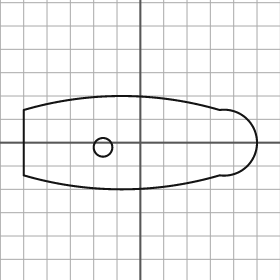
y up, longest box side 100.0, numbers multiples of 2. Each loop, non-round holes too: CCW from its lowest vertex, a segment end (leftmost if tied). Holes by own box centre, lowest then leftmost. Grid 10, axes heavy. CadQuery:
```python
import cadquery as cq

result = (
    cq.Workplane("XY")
    .moveTo(-50.0, -14.0)
    .threePointArc((-8.0, -20.0), (34.0, -14.0))
    .threePointArc((50.0, 0.0), (34.0, 14.0))
    .threePointArc((-8.0, 20.0), (-50.0, 14.0))
    .close()
    .moveTo(-16.0, -2.0)
    .circle(4.0)
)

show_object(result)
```